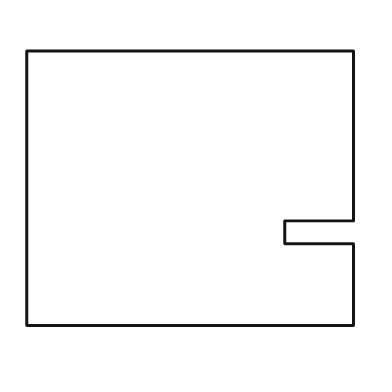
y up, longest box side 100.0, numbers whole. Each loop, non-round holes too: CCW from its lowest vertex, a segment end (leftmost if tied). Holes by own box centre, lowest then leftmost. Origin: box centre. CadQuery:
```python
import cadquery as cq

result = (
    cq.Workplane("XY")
    .moveTo(-50.0, -42.0)
    .lineTo(50.0, -42.0)
    .lineTo(50.0, -17.0)
    .lineTo(29.0, -17.0)
    .lineTo(29.0, -10.0)
    .lineTo(50.0, -10.0)
    .lineTo(50.0, 42.0)
    .lineTo(-50.0, 42.0)
    .close()
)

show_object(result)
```